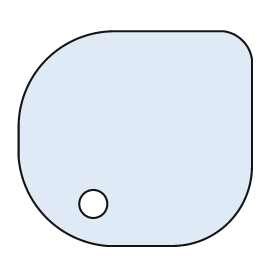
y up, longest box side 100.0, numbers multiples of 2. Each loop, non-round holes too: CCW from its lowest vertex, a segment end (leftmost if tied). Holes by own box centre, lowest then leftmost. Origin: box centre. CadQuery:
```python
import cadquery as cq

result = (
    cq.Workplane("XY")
    .moveTo(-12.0, -46.0)
    .lineTo(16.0, -46.0)
    .threePointArc((40.0, -36.0), (50.0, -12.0))
    .lineTo(50.0, 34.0)
    .threePointArc((46.0, 42.0), (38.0, 46.0))
    .lineTo(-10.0, 46.0)
    .threePointArc((-38.0, 34.0), (-50.0, 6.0))
    .lineTo(-50.0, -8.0)
    .threePointArc((-38.0, -34.0), (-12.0, -46.0))
    .close()
    .moveTo(-18.0, -28.0)
    .circle(6.0)
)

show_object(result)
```